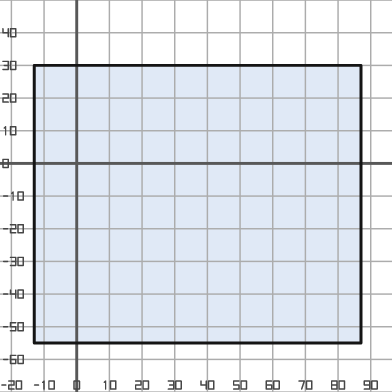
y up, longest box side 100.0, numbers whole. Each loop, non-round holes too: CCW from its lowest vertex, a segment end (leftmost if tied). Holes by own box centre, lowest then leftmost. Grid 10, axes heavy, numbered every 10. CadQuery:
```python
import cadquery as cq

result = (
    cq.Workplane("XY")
    .moveTo(-13.0, -55.0)
    .lineTo(87.0, -55.0)
    .lineTo(87.0, 30.0)
    .lineTo(-13.0, 30.0)
    .close()
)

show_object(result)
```